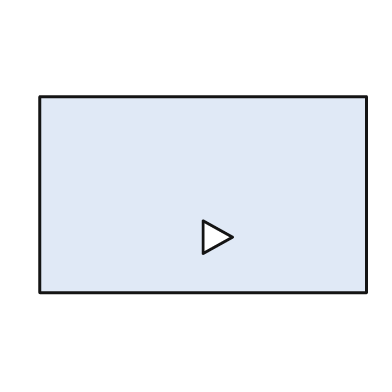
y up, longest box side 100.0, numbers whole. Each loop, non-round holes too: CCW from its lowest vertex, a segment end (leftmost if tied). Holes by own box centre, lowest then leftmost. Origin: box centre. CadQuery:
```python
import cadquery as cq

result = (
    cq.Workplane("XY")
    .moveTo(-50.0, -30.0)
    .lineTo(50.0, -30.0)
    .lineTo(50.0, 30.0)
    .lineTo(-50.0, 30.0)
    .close()
    .moveTo(0.0, -18.0)
    .lineTo(9.0, -13.0)
    .lineTo(0.0, -8.0)
    .close()
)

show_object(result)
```